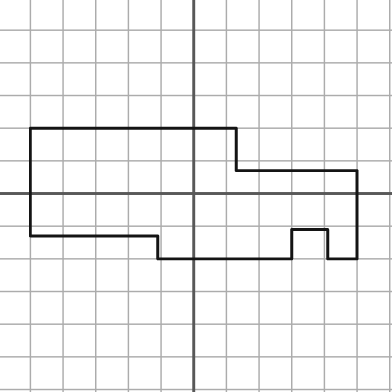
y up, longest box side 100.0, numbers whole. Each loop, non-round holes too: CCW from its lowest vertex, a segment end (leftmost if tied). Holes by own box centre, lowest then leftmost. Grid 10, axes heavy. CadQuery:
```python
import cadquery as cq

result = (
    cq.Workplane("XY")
    .moveTo(-11.0, -20.0)
    .lineTo(30.0, -20.0)
    .lineTo(30.0, -11.0)
    .lineTo(41.0, -11.0)
    .lineTo(41.0, -20.0)
    .lineTo(50.0, -20.0)
    .lineTo(50.0, 7.0)
    .lineTo(13.0, 7.0)
    .lineTo(13.0, 20.0)
    .lineTo(-50.0, 20.0)
    .lineTo(-50.0, -13.0)
    .lineTo(-11.0, -13.0)
    .close()
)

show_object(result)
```